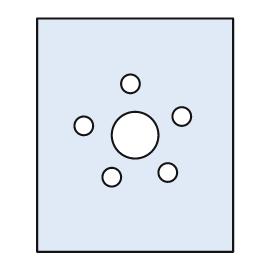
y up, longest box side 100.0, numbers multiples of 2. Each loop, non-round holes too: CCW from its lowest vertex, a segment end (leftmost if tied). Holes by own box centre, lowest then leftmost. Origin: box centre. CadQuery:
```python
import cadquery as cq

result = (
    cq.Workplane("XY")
    .moveTo(-42.0, -50.0)
    .lineTo(42.0, -50.0)
    .lineTo(42.0, 50.0)
    .lineTo(-42.0, 50.0)
    .close()
    .moveTo(-10.0, -18.0)
    .circle(4.0)
    .moveTo(14.0, -16.0)
    .circle(4.0)
    .moveTo(0.0, 0.0)
    .circle(10.0)
    .moveTo(-22.0, 4.0)
    .circle(4.0)
    .moveTo(20.0, 8.0)
    .circle(4.0)
    .moveTo(-2.0, 22.0)
    .circle(4.0)
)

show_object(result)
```